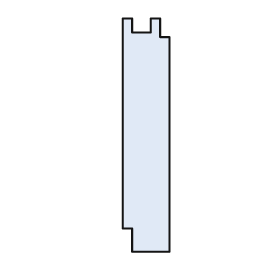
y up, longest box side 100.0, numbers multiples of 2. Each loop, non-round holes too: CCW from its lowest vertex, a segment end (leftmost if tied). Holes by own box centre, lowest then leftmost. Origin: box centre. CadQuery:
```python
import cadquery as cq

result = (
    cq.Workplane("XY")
    .moveTo(-6.0, -50.0)
    .lineTo(10.0, -50.0)
    .lineTo(10.0, 42.0)
    .lineTo(6.0, 42.0)
    .lineTo(6.0, 50.0)
    .lineTo(2.0, 50.0)
    .lineTo(2.0, 44.0)
    .lineTo(-6.0, 44.0)
    .lineTo(-6.0, 50.0)
    .lineTo(-10.0, 50.0)
    .lineTo(-10.0, -40.0)
    .lineTo(-6.0, -40.0)
    .close()
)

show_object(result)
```